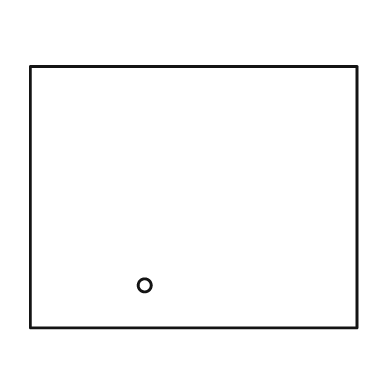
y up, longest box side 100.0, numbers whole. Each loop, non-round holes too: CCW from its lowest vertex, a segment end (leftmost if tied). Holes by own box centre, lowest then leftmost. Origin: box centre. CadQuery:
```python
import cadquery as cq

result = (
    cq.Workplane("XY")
    .moveTo(-50.0, -40.0)
    .lineTo(50.0, -40.0)
    .lineTo(50.0, 40.0)
    .lineTo(-50.0, 40.0)
    .close()
    .moveTo(-15.0, -27.0)
    .circle(2.0)
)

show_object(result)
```